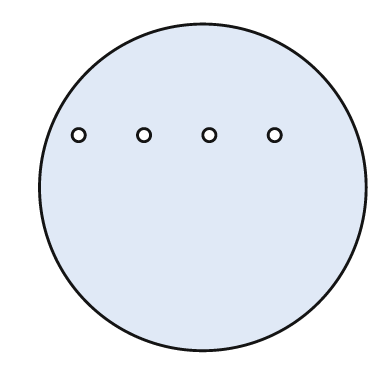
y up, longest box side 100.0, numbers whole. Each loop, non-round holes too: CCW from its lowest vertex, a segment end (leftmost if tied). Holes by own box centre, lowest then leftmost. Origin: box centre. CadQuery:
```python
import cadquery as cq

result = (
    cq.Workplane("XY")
    .moveTo(0.0, 0.0)
    .circle(50.0)
    .moveTo(-38.0, 16.0)
    .circle(2.0)
    .moveTo(-18.0, 16.0)
    .circle(2.0)
    .moveTo(2.0, 16.0)
    .circle(2.0)
    .moveTo(22.0, 16.0)
    .circle(2.0)
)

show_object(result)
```